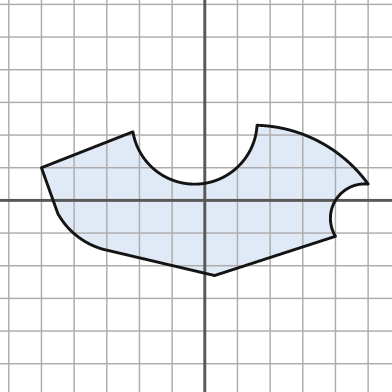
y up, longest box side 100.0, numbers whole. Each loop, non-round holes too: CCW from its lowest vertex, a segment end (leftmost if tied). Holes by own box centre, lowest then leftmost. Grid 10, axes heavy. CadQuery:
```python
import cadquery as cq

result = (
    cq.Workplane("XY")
    .moveTo(3.0, -23.0)
    .lineTo(40.0, -11.0)
    .threePointArc((40.0, 0.0), (50.0, 5.0))
    .threePointArc((35.0, 18.0), (16.0, 23.0))
    .threePointArc((-2.0, 5.0), (-22.0, 21.0))
    .lineTo(-50.0, 10.0)
    .lineTo(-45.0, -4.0)
    .threePointArc((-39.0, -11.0), (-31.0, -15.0))
    .close()
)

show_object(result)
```